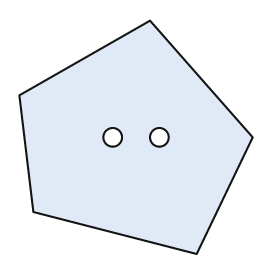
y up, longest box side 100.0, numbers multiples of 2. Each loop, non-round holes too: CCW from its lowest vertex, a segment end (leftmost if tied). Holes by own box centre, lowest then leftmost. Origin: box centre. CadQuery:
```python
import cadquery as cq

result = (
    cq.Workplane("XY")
    .moveTo(26.0, -50.0)
    .lineTo(50.0, 0.0)
    .lineTo(6.0, 50.0)
    .lineTo(-50.0, 18.0)
    .lineTo(-44.0, -32.0)
    .close()
    .moveTo(-10.0, 0.0)
    .circle(4.0)
    .moveTo(10.0, 0.0)
    .circle(4.0)
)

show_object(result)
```